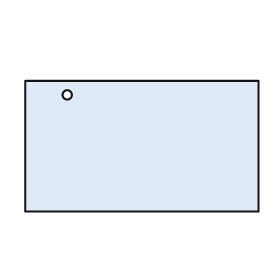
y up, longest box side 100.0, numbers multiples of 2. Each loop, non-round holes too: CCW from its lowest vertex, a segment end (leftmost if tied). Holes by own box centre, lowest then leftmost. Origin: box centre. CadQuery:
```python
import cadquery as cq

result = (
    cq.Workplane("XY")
    .moveTo(-50.0, -28.0)
    .lineTo(50.0, -28.0)
    .lineTo(50.0, 28.0)
    .lineTo(-50.0, 28.0)
    .close()
    .moveTo(-32.0, 22.0)
    .circle(2.0)
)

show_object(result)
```